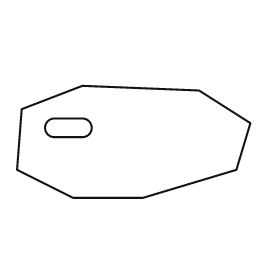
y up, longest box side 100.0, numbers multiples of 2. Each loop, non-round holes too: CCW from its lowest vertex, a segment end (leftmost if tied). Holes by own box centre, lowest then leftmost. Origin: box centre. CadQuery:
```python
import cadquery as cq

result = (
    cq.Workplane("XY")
    .moveTo(-26.0, -24.0)
    .lineTo(4.0, -24.0)
    .lineTo(44.0, -12.0)
    .lineTo(50.0, 8.0)
    .lineTo(28.0, 22.0)
    .lineTo(-22.0, 24.0)
    .lineTo(-48.0, 14.0)
    .lineTo(-50.0, -12.0)
    .close()
    .moveTo(-34.0, 2.0)
    .lineTo(-22.0, 2.0)
    .threePointArc((-18.0, 6.0), (-22.0, 10.0))
    .lineTo(-34.0, 10.0)
    .threePointArc((-38.0, 6.0), (-34.0, 2.0))
    .close()
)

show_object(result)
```